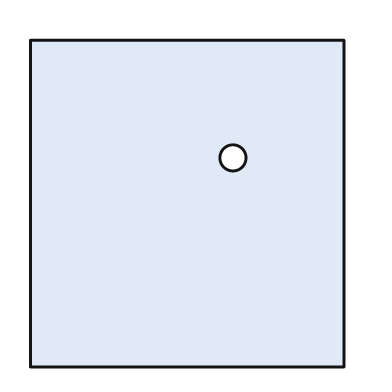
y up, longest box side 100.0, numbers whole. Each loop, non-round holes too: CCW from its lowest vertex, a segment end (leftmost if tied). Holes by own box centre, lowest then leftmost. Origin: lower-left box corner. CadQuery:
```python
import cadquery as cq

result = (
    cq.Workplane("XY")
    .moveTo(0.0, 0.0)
    .lineTo(96.0, 0.0)
    .lineTo(96.0, 100.0)
    .lineTo(0.0, 100.0)
    .close()
    .moveTo(62.0, 64.0)
    .circle(4.0)
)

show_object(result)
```